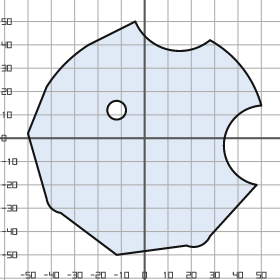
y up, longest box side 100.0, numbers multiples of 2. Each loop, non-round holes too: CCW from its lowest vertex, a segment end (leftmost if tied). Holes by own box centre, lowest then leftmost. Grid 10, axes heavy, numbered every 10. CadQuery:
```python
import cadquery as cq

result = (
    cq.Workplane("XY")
    .moveTo(-12.0, -50.0)
    .lineTo(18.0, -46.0)
    .threePointArc((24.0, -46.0), (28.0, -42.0))
    .lineTo(48.0, -20.0)
    .threePointArc((34.0, -2.0), (50.0, 14.0))
    .threePointArc((42.0, 30.0), (28.0, 42.0))
    .threePointArc((10.0, 38.0), (-4.0, 50.0))
    .lineTo(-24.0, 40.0)
    .threePointArc((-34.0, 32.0), (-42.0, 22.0))
    .lineTo(-50.0, 2.0)
    .lineTo(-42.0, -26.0)
    .threePointArc((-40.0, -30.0), (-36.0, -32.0))
    .close()
    .moveTo(-12.0, 12.0)
    .circle(4.0)
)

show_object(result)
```